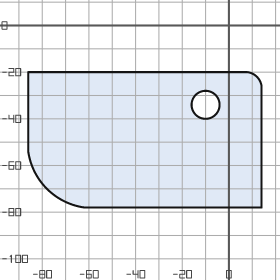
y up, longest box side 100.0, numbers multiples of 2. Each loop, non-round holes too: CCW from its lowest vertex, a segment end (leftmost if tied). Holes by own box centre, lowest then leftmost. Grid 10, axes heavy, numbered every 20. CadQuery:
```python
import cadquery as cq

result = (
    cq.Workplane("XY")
    .moveTo(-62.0, -78.0)
    .lineTo(14.0, -78.0)
    .lineTo(14.0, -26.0)
    .threePointArc((12.0, -22.0), (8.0, -20.0))
    .lineTo(-86.0, -20.0)
    .lineTo(-86.0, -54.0)
    .threePointArc((-78.0, -70.0), (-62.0, -78.0))
    .close()
    .moveTo(-10.0, -34.0)
    .circle(6.0)
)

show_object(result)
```